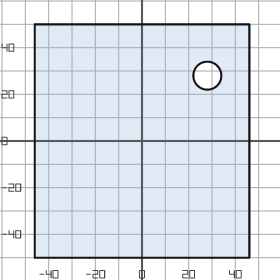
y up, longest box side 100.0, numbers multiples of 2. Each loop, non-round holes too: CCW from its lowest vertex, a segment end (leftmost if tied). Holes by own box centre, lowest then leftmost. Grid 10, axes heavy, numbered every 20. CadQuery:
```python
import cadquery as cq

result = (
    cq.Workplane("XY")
    .moveTo(-46.0, -50.0)
    .lineTo(46.0, -50.0)
    .lineTo(46.0, 50.0)
    .lineTo(-46.0, 50.0)
    .close()
    .moveTo(28.0, 28.0)
    .circle(6.0)
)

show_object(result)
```